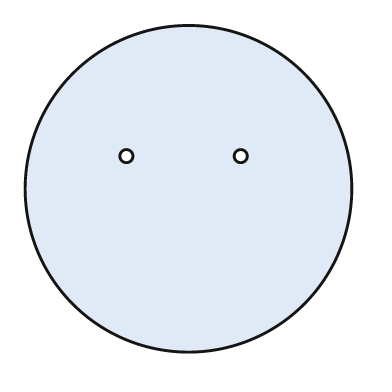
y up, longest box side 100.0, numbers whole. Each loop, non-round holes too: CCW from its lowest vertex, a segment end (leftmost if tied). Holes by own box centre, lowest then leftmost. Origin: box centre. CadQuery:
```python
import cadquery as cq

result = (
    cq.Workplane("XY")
    .moveTo(0.0, 0.0)
    .circle(50.0)
    .moveTo(-19.0, 10.0)
    .circle(2.0)
    .moveTo(16.0, 10.0)
    .circle(2.0)
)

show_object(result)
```